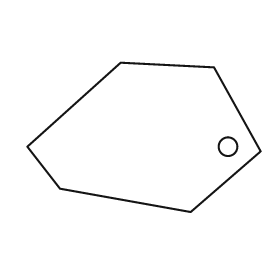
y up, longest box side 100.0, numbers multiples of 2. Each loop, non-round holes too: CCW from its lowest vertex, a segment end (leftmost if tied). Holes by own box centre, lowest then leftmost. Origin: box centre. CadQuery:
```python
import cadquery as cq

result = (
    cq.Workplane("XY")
    .moveTo(20.0, -32.0)
    .lineTo(50.0, -6.0)
    .lineTo(30.0, 30.0)
    .lineTo(-10.0, 32.0)
    .lineTo(-50.0, -4.0)
    .lineTo(-36.0, -22.0)
    .close()
    .moveTo(36.0, -4.0)
    .circle(4.0)
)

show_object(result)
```